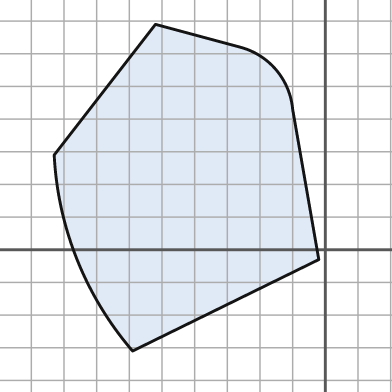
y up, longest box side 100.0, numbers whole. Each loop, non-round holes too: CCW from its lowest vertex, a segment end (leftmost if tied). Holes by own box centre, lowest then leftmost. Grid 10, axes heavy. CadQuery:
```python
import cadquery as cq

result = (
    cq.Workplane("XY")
    .moveTo(-59.0, -31.0)
    .lineTo(-2.0, -3.0)
    .lineTo(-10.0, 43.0)
    .threePointArc((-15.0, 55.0), (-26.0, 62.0))
    .lineTo(-52.0, 69.0)
    .lineTo(-83.0, 29.0)
    .threePointArc((-76.0, -3.0), (-59.0, -31.0))
    .close()
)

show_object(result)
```